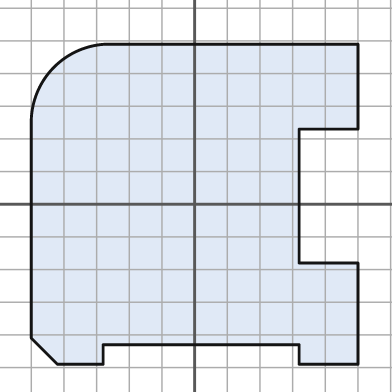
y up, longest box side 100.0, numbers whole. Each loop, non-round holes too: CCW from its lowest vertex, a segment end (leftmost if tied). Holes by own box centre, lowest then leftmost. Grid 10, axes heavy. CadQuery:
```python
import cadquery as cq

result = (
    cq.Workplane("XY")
    .moveTo(-42.0, -49.0)
    .lineTo(-28.0, -49.0)
    .lineTo(-28.0, -43.0)
    .lineTo(32.0, -43.0)
    .lineTo(32.0, -49.0)
    .lineTo(50.0, -49.0)
    .lineTo(50.0, -18.0)
    .lineTo(32.0, -18.0)
    .lineTo(32.0, 23.0)
    .lineTo(50.0, 23.0)
    .lineTo(50.0, 49.0)
    .lineTo(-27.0, 49.0)
    .threePointArc((-43.0, 42.0), (-50.0, 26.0))
    .lineTo(-50.0, -41.0)
    .close()
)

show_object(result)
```